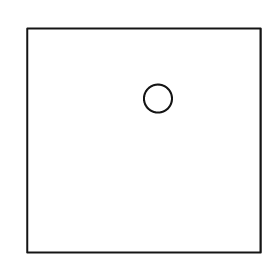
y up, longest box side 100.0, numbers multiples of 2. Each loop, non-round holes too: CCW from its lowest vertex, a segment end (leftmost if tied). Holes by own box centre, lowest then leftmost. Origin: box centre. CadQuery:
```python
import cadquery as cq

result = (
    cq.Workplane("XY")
    .moveTo(-50.0, -48.0)
    .lineTo(50.0, -48.0)
    .lineTo(50.0, 48.0)
    .lineTo(-50.0, 48.0)
    .close()
    .moveTo(6.0, 18.0)
    .circle(6.0)
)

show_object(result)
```